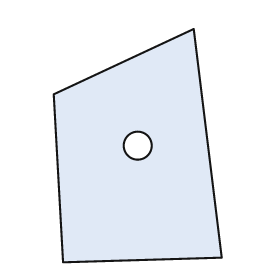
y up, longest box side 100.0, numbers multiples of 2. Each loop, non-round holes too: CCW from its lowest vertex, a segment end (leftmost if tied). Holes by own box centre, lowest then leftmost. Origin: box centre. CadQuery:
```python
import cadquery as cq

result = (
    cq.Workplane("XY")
    .moveTo(-32.0, -50.0)
    .lineTo(36.0, -48.0)
    .lineTo(24.0, 50.0)
    .lineTo(-36.0, 22.0)
    .close()
    .moveTo(0.0, 0.0)
    .circle(6.0)
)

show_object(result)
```